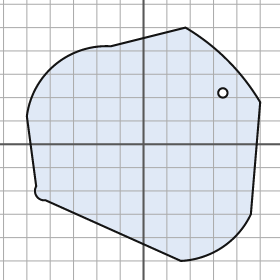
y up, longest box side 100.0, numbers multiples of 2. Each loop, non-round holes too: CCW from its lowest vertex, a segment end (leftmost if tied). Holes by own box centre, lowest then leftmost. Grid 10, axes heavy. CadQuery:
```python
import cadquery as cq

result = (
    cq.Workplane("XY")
    .moveTo(16.0, -50.0)
    .threePointArc((34.0, -44.0), (46.0, -30.0))
    .lineTo(50.0, 18.0)
    .threePointArc((36.0, 36.0), (18.0, 50.0))
    .lineTo(-14.0, 42.0)
    .threePointArc((-38.0, 34.0), (-50.0, 12.0))
    .lineTo(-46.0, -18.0)
    .threePointArc((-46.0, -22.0), (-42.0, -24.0))
    .close()
    .moveTo(34.0, 22.0)
    .circle(2.0)
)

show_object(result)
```